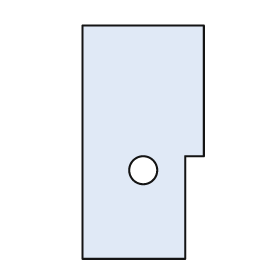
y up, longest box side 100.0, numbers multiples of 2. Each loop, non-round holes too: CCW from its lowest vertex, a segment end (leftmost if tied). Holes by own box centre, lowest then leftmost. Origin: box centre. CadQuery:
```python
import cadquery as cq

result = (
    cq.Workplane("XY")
    .moveTo(-26.0, -50.0)
    .lineTo(18.0, -50.0)
    .lineTo(18.0, -6.0)
    .lineTo(26.0, -6.0)
    .lineTo(26.0, 50.0)
    .lineTo(-26.0, 50.0)
    .close()
    .moveTo(0.0, -12.0)
    .circle(6.0)
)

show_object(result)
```